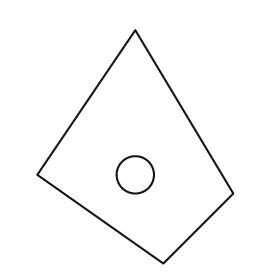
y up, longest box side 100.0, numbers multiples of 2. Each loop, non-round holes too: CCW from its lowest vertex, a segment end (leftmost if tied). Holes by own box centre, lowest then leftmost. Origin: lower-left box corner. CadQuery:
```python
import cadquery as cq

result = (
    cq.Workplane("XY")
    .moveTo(54.0, 0.0)
    .lineTo(84.0, 30.0)
    .lineTo(42.0, 100.0)
    .lineTo(0.0, 38.0)
    .close()
    .moveTo(42.0, 38.0)
    .circle(8.0)
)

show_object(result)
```